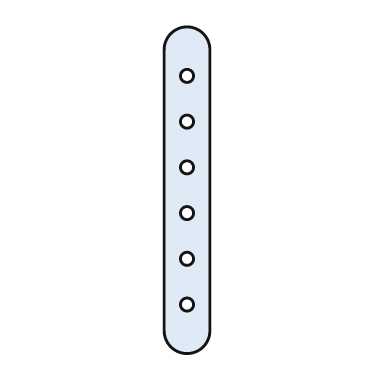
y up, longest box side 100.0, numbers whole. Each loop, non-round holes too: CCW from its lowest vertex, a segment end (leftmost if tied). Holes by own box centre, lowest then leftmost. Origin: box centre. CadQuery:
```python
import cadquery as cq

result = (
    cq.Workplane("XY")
    .moveTo(-7.0, -43.0)
    .threePointArc((0.0, -50.0), (7.0, -43.0))
    .lineTo(7.0, 43.0)
    .threePointArc((0.0, 50.0), (-7.0, 43.0))
    .close()
    .moveTo(0.0, -35.0)
    .circle(2.0)
    .moveTo(0.0, -21.0)
    .circle(2.0)
    .moveTo(0.0, -7.0)
    .circle(2.0)
    .moveTo(0.0, 7.0)
    .circle(2.0)
    .moveTo(0.0, 21.0)
    .circle(2.0)
    .moveTo(0.0, 35.0)
    .circle(2.0)
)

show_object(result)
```